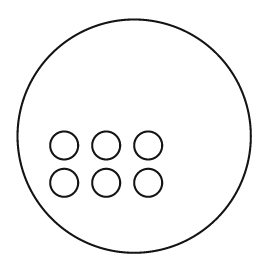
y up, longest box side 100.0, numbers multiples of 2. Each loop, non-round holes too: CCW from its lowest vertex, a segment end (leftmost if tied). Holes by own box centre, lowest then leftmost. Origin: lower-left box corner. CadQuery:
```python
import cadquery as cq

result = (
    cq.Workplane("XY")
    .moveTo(50.0, 50.0)
    .circle(50.0)
    .moveTo(20.0, 30.0)
    .circle(6.0)
    .moveTo(38.0, 30.0)
    .circle(6.0)
    .moveTo(56.0, 30.0)
    .circle(6.0)
    .moveTo(20.0, 46.0)
    .circle(6.0)
    .moveTo(38.0, 46.0)
    .circle(6.0)
    .moveTo(56.0, 46.0)
    .circle(6.0)
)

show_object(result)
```